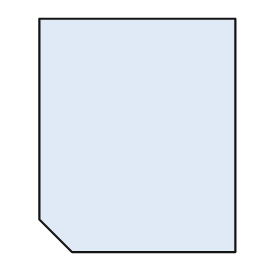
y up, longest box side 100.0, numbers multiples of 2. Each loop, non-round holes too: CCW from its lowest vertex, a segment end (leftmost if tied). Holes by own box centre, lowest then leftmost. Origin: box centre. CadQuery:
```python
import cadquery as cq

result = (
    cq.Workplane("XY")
    .moveTo(-28.0, -50.0)
    .lineTo(42.0, -50.0)
    .lineTo(42.0, 50.0)
    .lineTo(-42.0, 50.0)
    .lineTo(-42.0, -36.0)
    .close()
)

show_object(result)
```